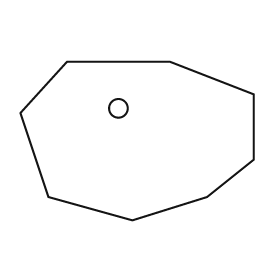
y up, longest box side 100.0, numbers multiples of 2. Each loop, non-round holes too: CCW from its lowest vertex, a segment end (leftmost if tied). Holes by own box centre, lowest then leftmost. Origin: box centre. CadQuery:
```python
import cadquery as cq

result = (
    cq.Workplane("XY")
    .moveTo(-2.0, -34.0)
    .lineTo(30.0, -24.0)
    .lineTo(50.0, -8.0)
    .lineTo(50.0, 20.0)
    .lineTo(14.0, 34.0)
    .lineTo(-30.0, 34.0)
    .lineTo(-50.0, 12.0)
    .lineTo(-38.0, -24.0)
    .close()
    .moveTo(-8.0, 14.0)
    .circle(4.0)
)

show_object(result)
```